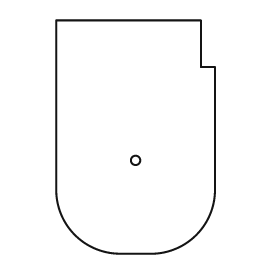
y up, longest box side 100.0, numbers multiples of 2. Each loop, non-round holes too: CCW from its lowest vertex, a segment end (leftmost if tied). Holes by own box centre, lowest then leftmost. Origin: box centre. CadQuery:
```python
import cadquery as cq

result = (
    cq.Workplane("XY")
    .moveTo(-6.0, -50.0)
    .lineTo(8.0, -50.0)
    .threePointArc((26.0, -42.0), (34.0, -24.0))
    .lineTo(34.0, 30.0)
    .lineTo(28.0, 30.0)
    .lineTo(28.0, 50.0)
    .lineTo(-34.0, 50.0)
    .lineTo(-34.0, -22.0)
    .threePointArc((-26.0, -42.0), (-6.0, -50.0))
    .close()
    .moveTo(0.0, -10.0)
    .circle(2.0)
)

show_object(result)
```